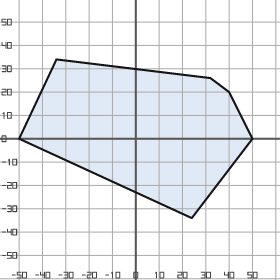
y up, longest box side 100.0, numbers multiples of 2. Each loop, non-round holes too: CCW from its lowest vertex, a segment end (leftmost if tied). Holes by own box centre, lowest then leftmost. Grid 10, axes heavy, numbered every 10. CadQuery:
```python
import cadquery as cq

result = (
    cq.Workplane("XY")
    .moveTo(24.0, -34.0)
    .lineTo(50.0, 0.0)
    .lineTo(40.0, 20.0)
    .lineTo(32.0, 26.0)
    .lineTo(-34.0, 34.0)
    .lineTo(-50.0, 0.0)
    .close()
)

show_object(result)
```